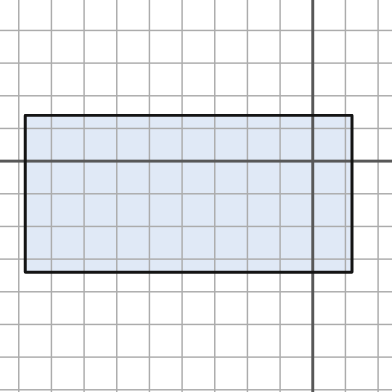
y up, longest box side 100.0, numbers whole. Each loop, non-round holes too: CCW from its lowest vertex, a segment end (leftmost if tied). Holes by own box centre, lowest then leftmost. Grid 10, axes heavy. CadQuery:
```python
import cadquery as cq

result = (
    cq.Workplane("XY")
    .moveTo(-88.0, -34.0)
    .lineTo(12.0, -34.0)
    .lineTo(12.0, 14.0)
    .lineTo(-88.0, 14.0)
    .close()
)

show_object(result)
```